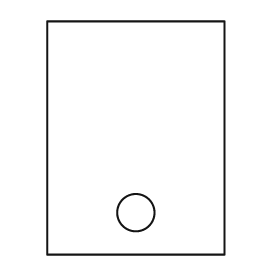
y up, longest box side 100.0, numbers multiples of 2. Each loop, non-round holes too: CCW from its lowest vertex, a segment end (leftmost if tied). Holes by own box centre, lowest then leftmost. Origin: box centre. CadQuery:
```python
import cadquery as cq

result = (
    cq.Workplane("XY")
    .moveTo(-38.0, -50.0)
    .lineTo(38.0, -50.0)
    .lineTo(38.0, 50.0)
    .lineTo(-38.0, 50.0)
    .close()
    .moveTo(0.0, -32.0)
    .circle(8.0)
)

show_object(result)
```